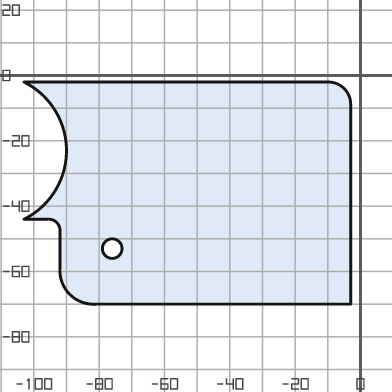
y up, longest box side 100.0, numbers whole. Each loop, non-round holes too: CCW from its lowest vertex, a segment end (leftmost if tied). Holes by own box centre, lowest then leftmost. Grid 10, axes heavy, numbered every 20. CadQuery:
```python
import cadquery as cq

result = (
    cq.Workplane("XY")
    .moveTo(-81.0, -70.0)
    .lineTo(-3.0, -70.0)
    .lineTo(-3.0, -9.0)
    .threePointArc((-5.0, -4.0), (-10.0, -2.0))
    .lineTo(-103.0, -2.0)
    .threePointArc((-90.0, -23.0), (-103.0, -44.0))
    .lineTo(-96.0, -44.0)
    .threePointArc((-93.0, -45.0), (-92.0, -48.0))
    .lineTo(-92.0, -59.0)
    .threePointArc((-89.0, -67.0), (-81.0, -70.0))
    .close()
    .moveTo(-76.0, -53.0)
    .circle(3.0)
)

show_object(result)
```